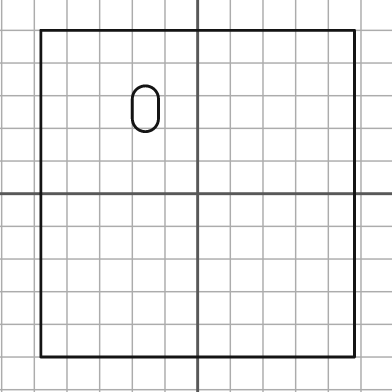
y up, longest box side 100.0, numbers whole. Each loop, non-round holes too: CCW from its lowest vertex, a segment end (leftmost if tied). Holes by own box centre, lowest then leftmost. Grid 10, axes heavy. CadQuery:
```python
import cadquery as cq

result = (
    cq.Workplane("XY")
    .moveTo(-48.0, -50.0)
    .lineTo(48.0, -50.0)
    .lineTo(48.0, 50.0)
    .lineTo(-48.0, 50.0)
    .close()
    .moveTo(-20.0, 23.0)
    .threePointArc((-16.0, 19.0), (-12.0, 23.0))
    .lineTo(-12.0, 29.0)
    .threePointArc((-16.0, 33.0), (-20.0, 29.0))
    .close()
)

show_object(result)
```